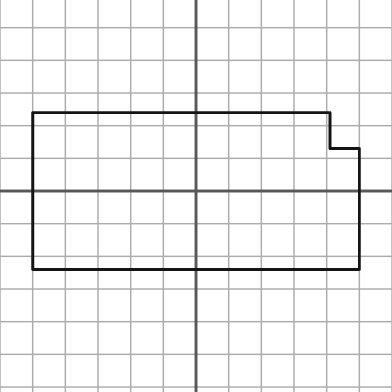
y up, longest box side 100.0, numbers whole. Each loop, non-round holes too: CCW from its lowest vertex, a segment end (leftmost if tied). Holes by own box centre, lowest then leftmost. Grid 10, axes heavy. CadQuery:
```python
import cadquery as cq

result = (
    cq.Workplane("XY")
    .moveTo(-50.0, -24.0)
    .lineTo(50.0, -24.0)
    .lineTo(50.0, 13.0)
    .lineTo(41.0, 13.0)
    .lineTo(41.0, 24.0)
    .lineTo(-50.0, 24.0)
    .close()
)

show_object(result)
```